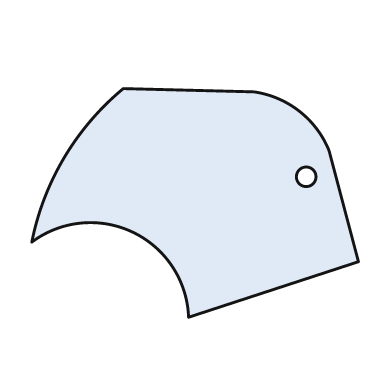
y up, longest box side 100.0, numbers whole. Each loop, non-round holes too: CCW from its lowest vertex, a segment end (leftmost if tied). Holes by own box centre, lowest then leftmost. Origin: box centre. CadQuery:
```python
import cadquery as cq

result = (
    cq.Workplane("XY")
    .moveTo(-2.0, -35.0)
    .lineTo(50.0, -18.0)
    .lineTo(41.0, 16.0)
    .threePointArc((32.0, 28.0), (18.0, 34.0))
    .lineTo(-22.0, 35.0)
    .threePointArc((-40.0, 14.0), (-50.0, -12.0))
    .threePointArc((-19.0, -9.0), (-2.0, -35.0))
    .close()
    .moveTo(34.0, 8.0)
    .circle(3.0)
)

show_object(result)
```